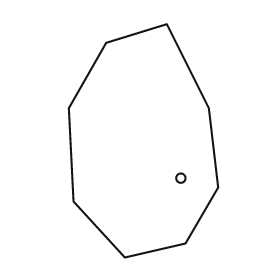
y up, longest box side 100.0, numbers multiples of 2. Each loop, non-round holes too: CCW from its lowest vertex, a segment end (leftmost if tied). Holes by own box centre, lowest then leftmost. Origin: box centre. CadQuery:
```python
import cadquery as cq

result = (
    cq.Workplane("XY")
    .moveTo(-8.0, -50.0)
    .lineTo(18.0, -44.0)
    .lineTo(32.0, -20.0)
    .lineTo(28.0, 14.0)
    .lineTo(10.0, 50.0)
    .lineTo(-16.0, 42.0)
    .lineTo(-32.0, 14.0)
    .lineTo(-30.0, -26.0)
    .close()
    .moveTo(16.0, -16.0)
    .circle(2.0)
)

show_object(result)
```